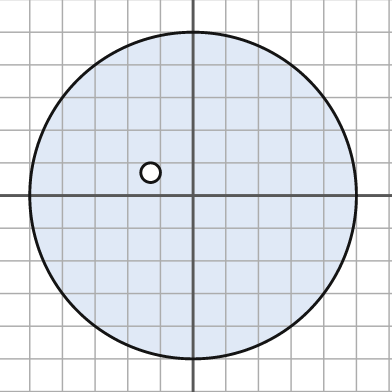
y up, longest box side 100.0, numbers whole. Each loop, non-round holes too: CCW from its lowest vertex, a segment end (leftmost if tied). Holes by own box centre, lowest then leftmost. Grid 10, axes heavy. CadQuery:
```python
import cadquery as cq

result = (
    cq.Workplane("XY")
    .moveTo(0.0, 0.0)
    .circle(50.0)
    .moveTo(-13.0, 7.0)
    .circle(3.0)
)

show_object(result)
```